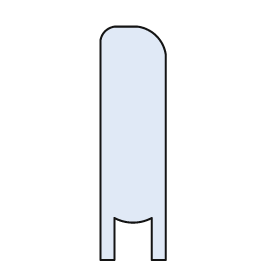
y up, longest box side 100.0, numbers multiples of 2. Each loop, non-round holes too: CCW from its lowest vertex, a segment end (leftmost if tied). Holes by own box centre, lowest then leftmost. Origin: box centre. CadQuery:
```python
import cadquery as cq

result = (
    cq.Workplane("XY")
    .moveTo(-14.0, -50.0)
    .lineTo(-8.0, -50.0)
    .lineTo(-8.0, -32.0)
    .threePointArc((0.0, -34.0), (8.0, -32.0))
    .lineTo(8.0, -50.0)
    .lineTo(14.0, -50.0)
    .lineTo(14.0, 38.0)
    .threePointArc((10.0, 46.0), (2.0, 50.0))
    .lineTo(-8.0, 50.0)
    .threePointArc((-12.0, 48.0), (-14.0, 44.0))
    .close()
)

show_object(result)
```